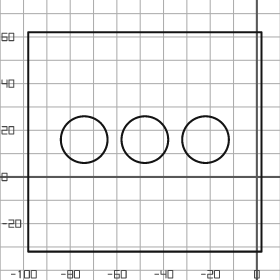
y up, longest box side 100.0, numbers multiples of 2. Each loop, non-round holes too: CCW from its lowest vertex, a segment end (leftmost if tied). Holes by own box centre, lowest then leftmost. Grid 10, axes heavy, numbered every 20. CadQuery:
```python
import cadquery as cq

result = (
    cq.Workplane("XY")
    .moveTo(-98.0, -32.0)
    .lineTo(2.0, -32.0)
    .lineTo(2.0, 62.0)
    .lineTo(-98.0, 62.0)
    .close()
    .moveTo(-74.0, 16.0)
    .circle(10.0)
    .moveTo(-48.0, 16.0)
    .circle(10.0)
    .moveTo(-22.0, 16.0)
    .circle(10.0)
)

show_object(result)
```